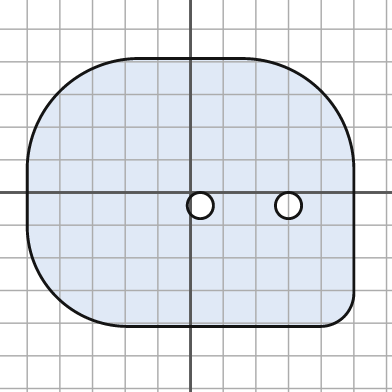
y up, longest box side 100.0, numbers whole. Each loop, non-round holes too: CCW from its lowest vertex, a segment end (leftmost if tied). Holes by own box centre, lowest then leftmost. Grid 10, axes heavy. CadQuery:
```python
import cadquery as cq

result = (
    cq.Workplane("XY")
    .moveTo(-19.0, -41.0)
    .lineTo(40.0, -41.0)
    .threePointArc((47.0, -38.0), (50.0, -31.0))
    .lineTo(50.0, 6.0)
    .threePointArc((40.0, 31.0), (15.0, 41.0))
    .lineTo(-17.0, 41.0)
    .threePointArc((-40.0, 31.0), (-50.0, 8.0))
    .lineTo(-50.0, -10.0)
    .threePointArc((-41.0, -32.0), (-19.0, -41.0))
    .close()
    .moveTo(3.0, -4.0)
    .circle(4.0)
    .moveTo(30.0, -4.0)
    .circle(4.0)
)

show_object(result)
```